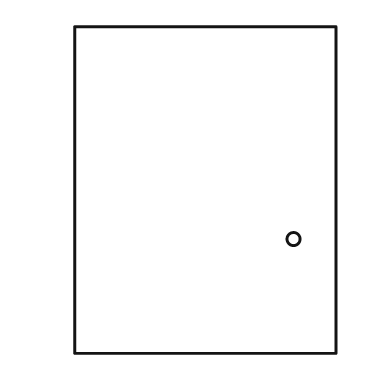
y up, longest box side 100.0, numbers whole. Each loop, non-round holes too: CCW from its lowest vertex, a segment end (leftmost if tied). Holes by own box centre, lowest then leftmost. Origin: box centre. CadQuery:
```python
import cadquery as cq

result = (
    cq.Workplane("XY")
    .moveTo(-40.0, -50.0)
    .lineTo(40.0, -50.0)
    .lineTo(40.0, 50.0)
    .lineTo(-40.0, 50.0)
    .close()
    .moveTo(27.0, -15.0)
    .circle(2.0)
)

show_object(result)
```